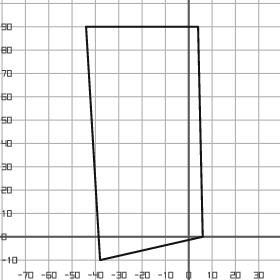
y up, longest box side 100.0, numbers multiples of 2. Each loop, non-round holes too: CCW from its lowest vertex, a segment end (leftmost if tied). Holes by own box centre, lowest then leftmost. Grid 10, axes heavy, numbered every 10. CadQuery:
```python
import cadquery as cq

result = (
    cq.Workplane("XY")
    .moveTo(-38.0, -10.0)
    .lineTo(6.0, 0.0)
    .lineTo(4.0, 90.0)
    .lineTo(-44.0, 90.0)
    .close()
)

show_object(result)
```